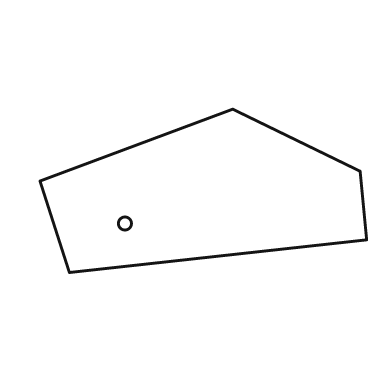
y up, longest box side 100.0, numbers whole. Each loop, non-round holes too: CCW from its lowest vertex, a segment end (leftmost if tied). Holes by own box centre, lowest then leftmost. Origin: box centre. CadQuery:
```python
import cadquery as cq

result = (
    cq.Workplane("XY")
    .moveTo(-41.0, -25.0)
    .lineTo(50.0, -15.0)
    .lineTo(48.0, 6.0)
    .lineTo(9.0, 25.0)
    .lineTo(-50.0, 3.0)
    .close()
    .moveTo(-24.0, -10.0)
    .circle(2.0)
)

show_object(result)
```